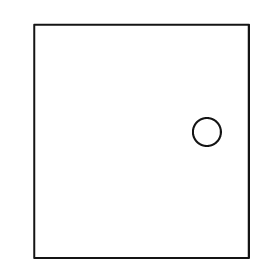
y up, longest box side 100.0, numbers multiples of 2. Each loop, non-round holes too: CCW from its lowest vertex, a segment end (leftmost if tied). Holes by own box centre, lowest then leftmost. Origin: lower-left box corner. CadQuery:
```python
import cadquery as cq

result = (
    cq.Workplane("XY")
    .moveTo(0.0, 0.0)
    .lineTo(92.0, 0.0)
    .lineTo(92.0, 100.0)
    .lineTo(0.0, 100.0)
    .close()
    .moveTo(74.0, 54.0)
    .circle(6.0)
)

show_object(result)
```